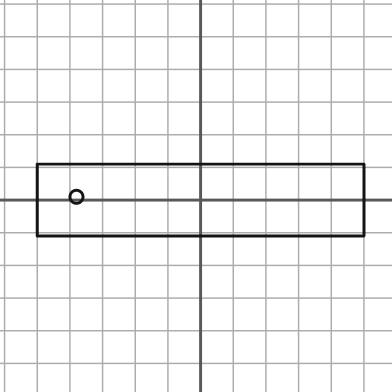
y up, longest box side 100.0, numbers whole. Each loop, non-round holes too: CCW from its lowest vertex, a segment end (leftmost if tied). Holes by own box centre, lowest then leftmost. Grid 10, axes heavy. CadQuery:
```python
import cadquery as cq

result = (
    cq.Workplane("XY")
    .moveTo(-50.0, -11.0)
    .lineTo(50.0, -11.0)
    .lineTo(50.0, 11.0)
    .lineTo(-50.0, 11.0)
    .close()
    .moveTo(-38.0, 1.0)
    .circle(2.0)
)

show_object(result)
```